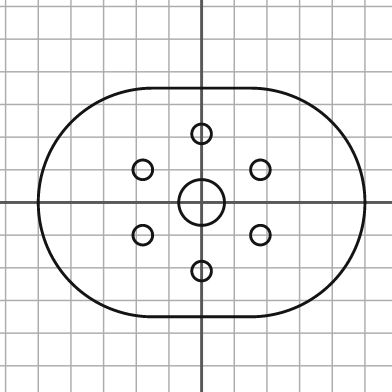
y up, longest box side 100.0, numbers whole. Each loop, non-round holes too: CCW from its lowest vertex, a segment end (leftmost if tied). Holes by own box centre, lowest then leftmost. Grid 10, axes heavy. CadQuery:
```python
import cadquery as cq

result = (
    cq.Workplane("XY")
    .moveTo(-15.0, -35.0)
    .lineTo(15.0, -35.0)
    .threePointArc((50.0, 0.0), (15.0, 35.0))
    .lineTo(-15.0, 35.0)
    .threePointArc((-50.0, 0.0), (-15.0, -35.0))
    .close()
    .moveTo(0.0, -21.0)
    .circle(3.0)
    .moveTo(-18.0, -10.0)
    .circle(3.0)
    .moveTo(18.0, -10.0)
    .circle(3.0)
    .moveTo(0.0, 0.0)
    .circle(7.0)
    .moveTo(-18.0, 10.0)
    .circle(3.0)
    .moveTo(18.0, 10.0)
    .circle(3.0)
    .moveTo(0.0, 21.0)
    .circle(3.0)
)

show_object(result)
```